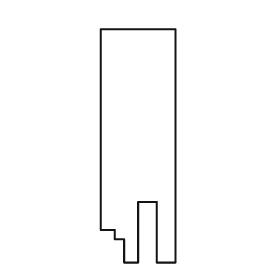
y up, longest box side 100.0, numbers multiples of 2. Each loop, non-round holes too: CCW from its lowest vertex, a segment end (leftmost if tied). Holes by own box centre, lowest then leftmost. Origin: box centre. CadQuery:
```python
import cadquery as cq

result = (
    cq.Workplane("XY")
    .moveTo(-6.0, -50.0)
    .lineTo(0.0, -50.0)
    .lineTo(0.0, -24.0)
    .lineTo(8.0, -24.0)
    .lineTo(8.0, -50.0)
    .lineTo(16.0, -50.0)
    .lineTo(16.0, 50.0)
    .lineTo(-16.0, 50.0)
    .lineTo(-16.0, -36.0)
    .lineTo(-10.0, -36.0)
    .lineTo(-10.0, -40.0)
    .lineTo(-6.0, -40.0)
    .close()
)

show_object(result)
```